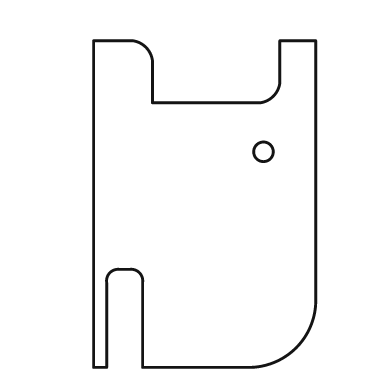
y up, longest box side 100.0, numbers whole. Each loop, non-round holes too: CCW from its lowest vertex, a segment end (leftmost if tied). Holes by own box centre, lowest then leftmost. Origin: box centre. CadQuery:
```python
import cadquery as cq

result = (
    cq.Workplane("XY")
    .moveTo(-34.0, -50.0)
    .lineTo(-30.0, -50.0)
    .lineTo(-30.0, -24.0)
    .threePointArc((-29.0, -21.0), (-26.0, -20.0))
    .lineTo(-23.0, -20.0)
    .threePointArc((-20.0, -21.0), (-19.0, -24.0))
    .lineTo(-19.0, -50.0)
    .lineTo(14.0, -50.0)
    .threePointArc((28.0, -44.0), (34.0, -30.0))
    .lineTo(34.0, 50.0)
    .lineTo(23.0, 50.0)
    .lineTo(23.0, 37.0)
    .threePointArc((21.0, 33.0), (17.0, 31.0))
    .lineTo(-16.0, 31.0)
    .lineTo(-16.0, 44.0)
    .threePointArc((-18.0, 48.0), (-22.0, 50.0))
    .lineTo(-34.0, 50.0)
    .close()
    .moveTo(18.0, 16.0)
    .circle(3.0)
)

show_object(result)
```